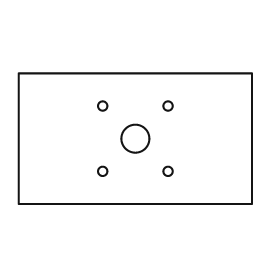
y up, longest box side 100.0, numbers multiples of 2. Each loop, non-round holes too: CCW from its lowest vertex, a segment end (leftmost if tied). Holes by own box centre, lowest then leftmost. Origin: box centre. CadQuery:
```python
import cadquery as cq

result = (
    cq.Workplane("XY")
    .moveTo(-50.0, -28.0)
    .lineTo(50.0, -28.0)
    .lineTo(50.0, 28.0)
    .lineTo(-50.0, 28.0)
    .close()
    .moveTo(-14.0, -14.0)
    .circle(2.0)
    .moveTo(14.0, -14.0)
    .circle(2.0)
    .moveTo(0.0, 0.0)
    .circle(6.0)
    .moveTo(-14.0, 14.0)
    .circle(2.0)
    .moveTo(14.0, 14.0)
    .circle(2.0)
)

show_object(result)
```